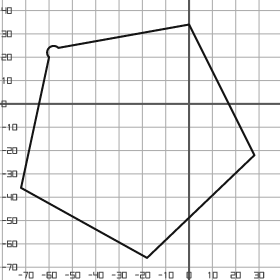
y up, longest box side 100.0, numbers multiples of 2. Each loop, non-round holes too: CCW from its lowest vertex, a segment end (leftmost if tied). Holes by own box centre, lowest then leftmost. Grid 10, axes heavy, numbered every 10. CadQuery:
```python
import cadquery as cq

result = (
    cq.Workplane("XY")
    .moveTo(-18.0, -66.0)
    .lineTo(28.0, -22.0)
    .lineTo(0.0, 34.0)
    .lineTo(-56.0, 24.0)
    .threePointArc((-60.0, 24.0), (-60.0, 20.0))
    .lineTo(-72.0, -36.0)
    .close()
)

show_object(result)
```